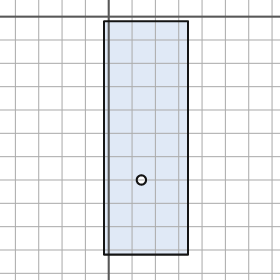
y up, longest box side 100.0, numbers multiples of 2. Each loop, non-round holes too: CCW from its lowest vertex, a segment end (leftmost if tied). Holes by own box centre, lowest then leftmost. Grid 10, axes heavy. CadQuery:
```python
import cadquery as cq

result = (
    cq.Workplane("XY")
    .moveTo(-2.0, -102.0)
    .lineTo(34.0, -102.0)
    .lineTo(34.0, -2.0)
    .lineTo(-2.0, -2.0)
    .close()
    .moveTo(14.0, -70.0)
    .circle(2.0)
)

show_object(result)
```